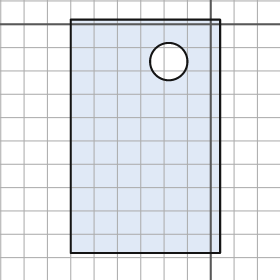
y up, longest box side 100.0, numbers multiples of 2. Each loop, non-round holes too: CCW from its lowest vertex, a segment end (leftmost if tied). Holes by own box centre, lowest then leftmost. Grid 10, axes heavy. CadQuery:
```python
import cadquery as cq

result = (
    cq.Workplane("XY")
    .moveTo(-60.0, -98.0)
    .lineTo(4.0, -98.0)
    .lineTo(4.0, 2.0)
    .lineTo(-60.0, 2.0)
    .close()
    .moveTo(-18.0, -16.0)
    .circle(8.0)
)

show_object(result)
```